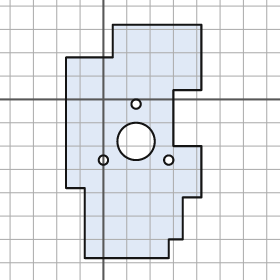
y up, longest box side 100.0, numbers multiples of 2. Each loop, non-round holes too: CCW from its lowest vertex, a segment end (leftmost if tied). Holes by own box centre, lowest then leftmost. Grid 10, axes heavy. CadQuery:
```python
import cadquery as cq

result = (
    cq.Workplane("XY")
    .moveTo(-8.0, -68.0)
    .lineTo(28.0, -68.0)
    .lineTo(28.0, -60.0)
    .lineTo(34.0, -60.0)
    .lineTo(34.0, -42.0)
    .lineTo(42.0, -42.0)
    .lineTo(42.0, -20.0)
    .lineTo(30.0, -20.0)
    .lineTo(30.0, 4.0)
    .lineTo(42.0, 4.0)
    .lineTo(42.0, 32.0)
    .lineTo(4.0, 32.0)
    .lineTo(4.0, 18.0)
    .lineTo(-16.0, 18.0)
    .lineTo(-16.0, -38.0)
    .lineTo(-8.0, -38.0)
    .close()
    .moveTo(0.0, -26.0)
    .circle(2.0)
    .moveTo(28.0, -26.0)
    .circle(2.0)
    .moveTo(14.0, -18.0)
    .circle(8.0)
    .moveTo(14.0, -2.0)
    .circle(2.0)
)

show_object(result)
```